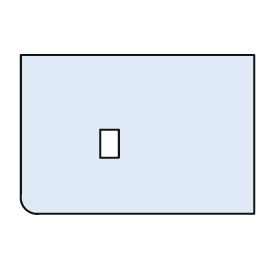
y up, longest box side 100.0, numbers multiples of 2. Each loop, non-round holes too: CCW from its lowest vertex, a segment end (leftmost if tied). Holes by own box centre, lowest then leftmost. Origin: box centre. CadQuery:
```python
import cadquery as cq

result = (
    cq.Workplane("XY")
    .moveTo(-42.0, -34.0)
    .lineTo(50.0, -34.0)
    .lineTo(50.0, 34.0)
    .lineTo(-50.0, 34.0)
    .lineTo(-50.0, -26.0)
    .threePointArc((-48.0, -32.0), (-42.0, -34.0))
    .close()
    .moveTo(-16.0, -10.0)
    .lineTo(-8.0, -10.0)
    .lineTo(-8.0, 2.0)
    .lineTo(-16.0, 2.0)
    .close()
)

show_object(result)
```